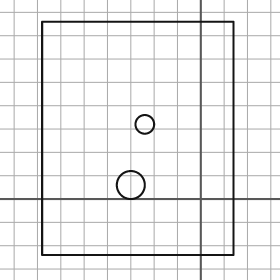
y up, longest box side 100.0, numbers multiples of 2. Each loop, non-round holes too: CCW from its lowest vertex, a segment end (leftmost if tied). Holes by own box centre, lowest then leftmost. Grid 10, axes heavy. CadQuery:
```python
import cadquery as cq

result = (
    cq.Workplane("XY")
    .moveTo(-68.0, -24.0)
    .lineTo(14.0, -24.0)
    .lineTo(14.0, 76.0)
    .lineTo(-68.0, 76.0)
    .close()
    .moveTo(-30.0, 6.0)
    .circle(6.0)
    .moveTo(-24.0, 32.0)
    .circle(4.0)
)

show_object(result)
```